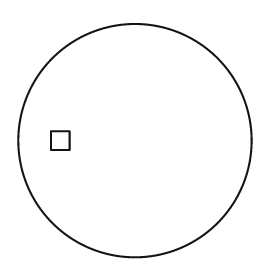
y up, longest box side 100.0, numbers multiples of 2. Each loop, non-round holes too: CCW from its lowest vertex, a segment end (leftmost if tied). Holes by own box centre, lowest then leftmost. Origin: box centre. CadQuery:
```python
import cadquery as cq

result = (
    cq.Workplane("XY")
    .moveTo(0.0, 0.0)
    .circle(50.0)
    .moveTo(-36.0, -4.0)
    .lineTo(-28.0, -4.0)
    .lineTo(-28.0, 4.0)
    .lineTo(-36.0, 4.0)
    .close()
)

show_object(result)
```